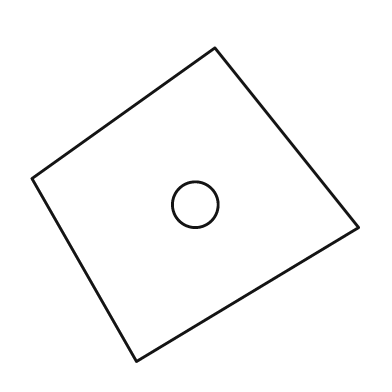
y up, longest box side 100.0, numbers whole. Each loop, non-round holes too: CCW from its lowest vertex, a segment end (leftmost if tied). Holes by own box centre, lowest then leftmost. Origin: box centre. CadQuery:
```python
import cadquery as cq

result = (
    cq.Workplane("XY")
    .moveTo(-18.0, -48.0)
    .lineTo(50.0, -7.0)
    .lineTo(6.0, 48.0)
    .lineTo(-50.0, 8.0)
    .close()
    .moveTo(0.0, 0.0)
    .circle(7.0)
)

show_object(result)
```